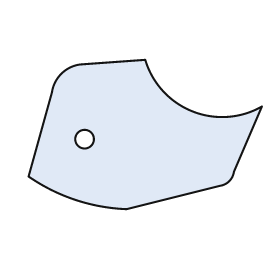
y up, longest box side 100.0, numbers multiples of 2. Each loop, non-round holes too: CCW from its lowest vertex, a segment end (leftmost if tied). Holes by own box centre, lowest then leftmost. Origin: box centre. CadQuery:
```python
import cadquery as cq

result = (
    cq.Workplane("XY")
    .moveTo(-8.0, -32.0)
    .lineTo(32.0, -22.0)
    .threePointArc((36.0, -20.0), (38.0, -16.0))
    .lineTo(50.0, 12.0)
    .threePointArc((20.0, 10.0), (0.0, 32.0))
    .lineTo(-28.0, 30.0)
    .threePointArc((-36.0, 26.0), (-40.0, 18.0))
    .lineTo(-50.0, -18.0)
    .threePointArc((-30.0, -28.0), (-8.0, -32.0))
    .close()
    .moveTo(-26.0, -2.0)
    .circle(4.0)
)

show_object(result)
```